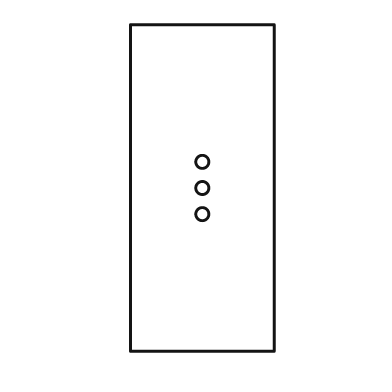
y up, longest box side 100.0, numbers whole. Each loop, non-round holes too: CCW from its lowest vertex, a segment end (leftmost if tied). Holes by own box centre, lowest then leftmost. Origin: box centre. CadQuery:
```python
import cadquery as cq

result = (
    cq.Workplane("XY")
    .moveTo(-22.0, -50.0)
    .lineTo(22.0, -50.0)
    .lineTo(22.0, 50.0)
    .lineTo(-22.0, 50.0)
    .close()
    .moveTo(0.0, -8.0)
    .circle(2.0)
    .moveTo(0.0, 0.0)
    .circle(2.0)
    .moveTo(0.0, 8.0)
    .circle(2.0)
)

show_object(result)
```